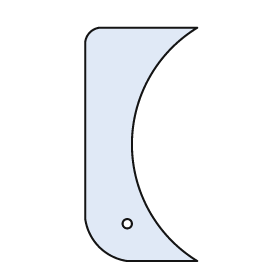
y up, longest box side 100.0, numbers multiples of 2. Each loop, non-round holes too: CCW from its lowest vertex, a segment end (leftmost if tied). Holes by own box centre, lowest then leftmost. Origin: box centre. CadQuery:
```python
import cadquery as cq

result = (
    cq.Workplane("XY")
    .moveTo(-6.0, -50.0)
    .lineTo(24.0, -50.0)
    .threePointArc((-4.0, 0.0), (24.0, 50.0))
    .lineTo(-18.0, 50.0)
    .threePointArc((-22.0, 48.0), (-24.0, 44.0))
    .lineTo(-24.0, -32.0)
    .threePointArc((-18.0, -44.0), (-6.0, -50.0))
    .close()
    .moveTo(-6.0, -34.0)
    .circle(2.0)
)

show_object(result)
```